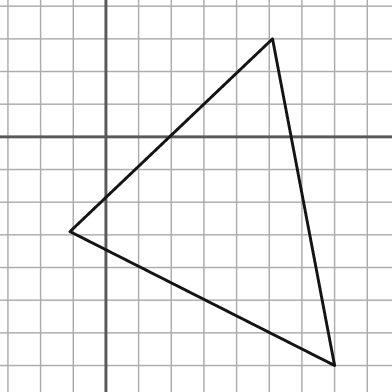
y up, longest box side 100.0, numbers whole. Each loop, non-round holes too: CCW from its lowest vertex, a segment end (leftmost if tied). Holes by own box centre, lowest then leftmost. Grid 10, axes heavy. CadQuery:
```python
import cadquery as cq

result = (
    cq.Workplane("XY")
    .moveTo(70.0, -70.0)
    .lineTo(51.0, 30.0)
    .lineTo(-11.0, -29.0)
    .close()
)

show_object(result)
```